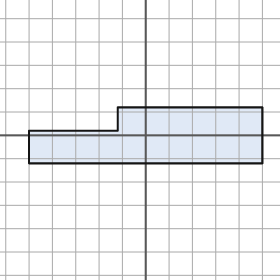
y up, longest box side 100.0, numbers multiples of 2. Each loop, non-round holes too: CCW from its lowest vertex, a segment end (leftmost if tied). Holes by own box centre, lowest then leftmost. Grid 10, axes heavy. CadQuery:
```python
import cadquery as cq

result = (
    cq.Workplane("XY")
    .moveTo(-50.0, -12.0)
    .lineTo(50.0, -12.0)
    .lineTo(50.0, 12.0)
    .lineTo(-12.0, 12.0)
    .lineTo(-12.0, 2.0)
    .lineTo(-50.0, 2.0)
    .close()
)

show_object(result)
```